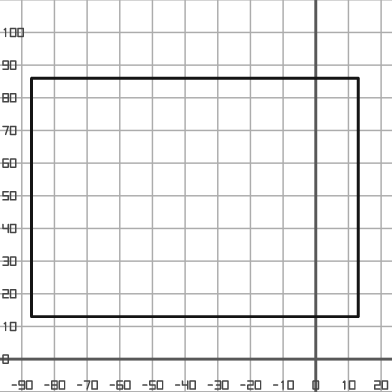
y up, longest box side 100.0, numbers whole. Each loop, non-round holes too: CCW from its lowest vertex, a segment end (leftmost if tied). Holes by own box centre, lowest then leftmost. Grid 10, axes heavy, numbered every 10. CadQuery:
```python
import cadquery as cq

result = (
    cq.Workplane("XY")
    .moveTo(-87.0, 13.0)
    .lineTo(13.0, 13.0)
    .lineTo(13.0, 86.0)
    .lineTo(-87.0, 86.0)
    .close()
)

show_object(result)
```